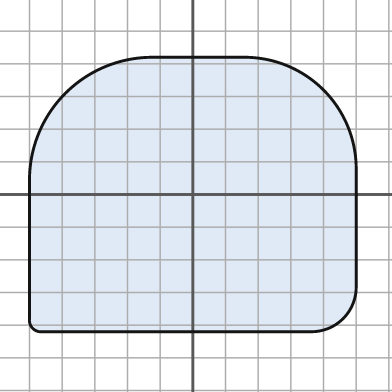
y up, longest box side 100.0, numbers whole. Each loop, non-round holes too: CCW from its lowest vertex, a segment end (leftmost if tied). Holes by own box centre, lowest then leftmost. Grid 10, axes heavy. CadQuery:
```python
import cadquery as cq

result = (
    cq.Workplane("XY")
    .moveTo(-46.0, -42.0)
    .lineTo(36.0, -42.0)
    .threePointArc((46.0, -38.0), (50.0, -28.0))
    .lineTo(50.0, 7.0)
    .threePointArc((40.0, 32.0), (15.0, 42.0))
    .lineTo(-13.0, 42.0)
    .threePointArc((-39.0, 31.0), (-50.0, 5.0))
    .lineTo(-50.0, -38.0)
    .threePointArc((-49.0, -41.0), (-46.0, -42.0))
    .close()
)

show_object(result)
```